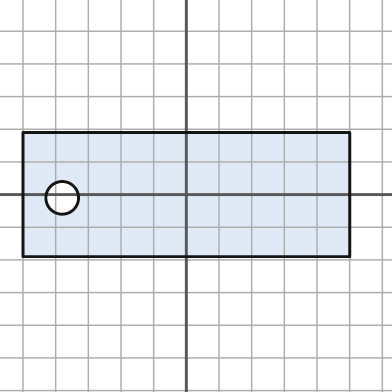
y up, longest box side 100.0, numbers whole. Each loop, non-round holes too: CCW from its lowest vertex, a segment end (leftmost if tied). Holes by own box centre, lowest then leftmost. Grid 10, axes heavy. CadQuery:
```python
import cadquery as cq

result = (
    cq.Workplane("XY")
    .moveTo(-50.0, -19.0)
    .lineTo(50.0, -19.0)
    .lineTo(50.0, 19.0)
    .lineTo(-50.0, 19.0)
    .close()
    .moveTo(-38.0, -1.0)
    .circle(5.0)
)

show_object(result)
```